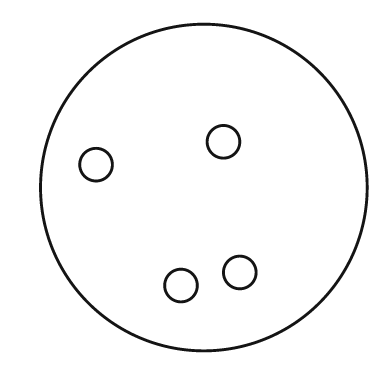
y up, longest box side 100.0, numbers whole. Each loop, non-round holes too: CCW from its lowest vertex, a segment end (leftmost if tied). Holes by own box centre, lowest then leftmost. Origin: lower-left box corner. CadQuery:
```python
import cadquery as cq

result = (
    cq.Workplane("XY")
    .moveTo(50.0, 50.0)
    .circle(50.0)
    .moveTo(43.0, 20.0)
    .circle(5.0)
    .moveTo(61.0, 24.0)
    .circle(5.0)
    .moveTo(17.0, 57.0)
    .circle(5.0)
    .moveTo(56.0, 64.0)
    .circle(5.0)
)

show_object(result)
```